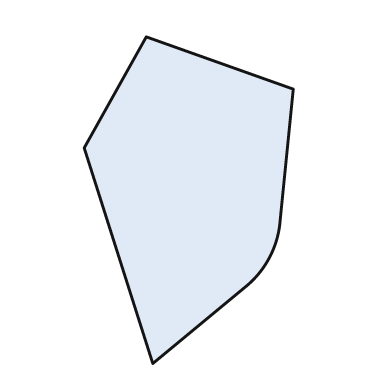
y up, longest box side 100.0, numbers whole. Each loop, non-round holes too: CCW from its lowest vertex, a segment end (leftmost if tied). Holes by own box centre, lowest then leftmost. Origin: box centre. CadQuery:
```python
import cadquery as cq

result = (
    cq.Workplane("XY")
    .moveTo(-11.0, -50.0)
    .lineTo(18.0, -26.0)
    .threePointArc((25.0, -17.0), (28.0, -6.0))
    .lineTo(32.0, 34.0)
    .lineTo(-13.0, 50.0)
    .lineTo(-32.0, 16.0)
    .close()
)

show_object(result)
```